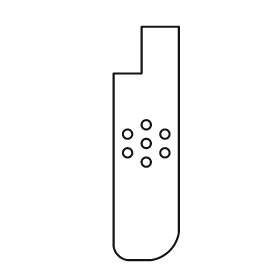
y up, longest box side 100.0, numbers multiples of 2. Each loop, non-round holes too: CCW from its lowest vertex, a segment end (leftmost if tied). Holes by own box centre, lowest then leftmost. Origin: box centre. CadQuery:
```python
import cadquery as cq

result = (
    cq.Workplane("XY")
    .moveTo(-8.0, -50.0)
    .lineTo(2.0, -50.0)
    .threePointArc((10.0, -46.0), (14.0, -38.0))
    .lineTo(14.0, 50.0)
    .lineTo(-2.0, 50.0)
    .lineTo(-2.0, 30.0)
    .lineTo(-14.0, 30.0)
    .lineTo(-14.0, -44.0)
    .threePointArc((-12.0, -48.0), (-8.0, -50.0))
    .close()
    .moveTo(0.0, -8.0)
    .circle(2.0)
    .moveTo(-8.0, -4.0)
    .circle(2.0)
    .moveTo(8.0, -4.0)
    .circle(2.0)
    .moveTo(0.0, 0.0)
    .circle(2.0)
    .moveTo(-8.0, 4.0)
    .circle(2.0)
    .moveTo(8.0, 4.0)
    .circle(2.0)
    .moveTo(0.0, 8.0)
    .circle(2.0)
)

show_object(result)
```